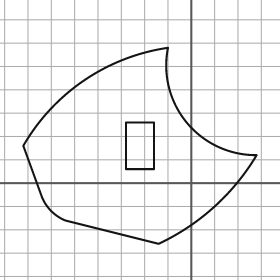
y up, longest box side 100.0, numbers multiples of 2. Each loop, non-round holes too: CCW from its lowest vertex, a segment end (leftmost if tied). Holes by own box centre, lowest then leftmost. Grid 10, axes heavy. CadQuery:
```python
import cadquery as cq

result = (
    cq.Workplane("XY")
    .moveTo(-14.0, -26.0)
    .threePointArc((10.0, -10.0), (28.0, 12.0))
    .threePointArc((-2.0, 26.0), (-10.0, 58.0))
    .threePointArc((-46.0, 44.0), (-72.0, 16.0))
    .lineTo(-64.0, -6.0)
    .threePointArc((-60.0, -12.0), (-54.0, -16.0))
    .close()
    .moveTo(-28.0, 6.0)
    .lineTo(-16.0, 6.0)
    .lineTo(-16.0, 26.0)
    .lineTo(-28.0, 26.0)
    .close()
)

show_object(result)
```